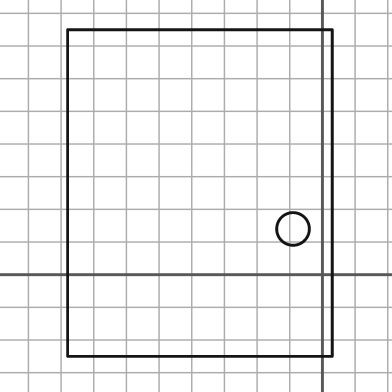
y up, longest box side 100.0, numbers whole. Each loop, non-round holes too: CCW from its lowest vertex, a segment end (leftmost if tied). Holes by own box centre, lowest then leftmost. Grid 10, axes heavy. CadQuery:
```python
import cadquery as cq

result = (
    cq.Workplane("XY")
    .moveTo(-78.0, -25.0)
    .lineTo(3.0, -25.0)
    .lineTo(3.0, 75.0)
    .lineTo(-78.0, 75.0)
    .close()
    .moveTo(-9.0, 14.0)
    .circle(5.0)
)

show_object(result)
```